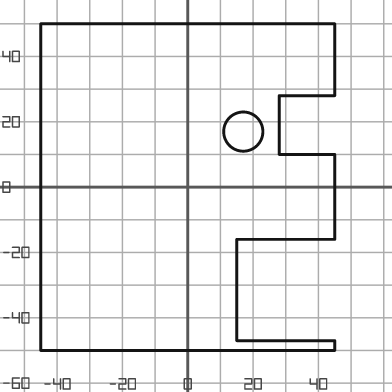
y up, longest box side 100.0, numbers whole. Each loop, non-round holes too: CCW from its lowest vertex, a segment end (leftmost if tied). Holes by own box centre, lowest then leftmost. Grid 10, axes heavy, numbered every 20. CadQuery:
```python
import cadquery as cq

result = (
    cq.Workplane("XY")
    .moveTo(-45.0, -50.0)
    .lineTo(45.0, -50.0)
    .lineTo(45.0, -47.0)
    .lineTo(15.0, -47.0)
    .lineTo(15.0, -16.0)
    .lineTo(45.0, -16.0)
    .lineTo(45.0, 10.0)
    .lineTo(28.0, 10.0)
    .lineTo(28.0, 28.0)
    .lineTo(45.0, 28.0)
    .lineTo(45.0, 50.0)
    .lineTo(-45.0, 50.0)
    .close()
    .moveTo(17.0, 17.0)
    .circle(6.0)
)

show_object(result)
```